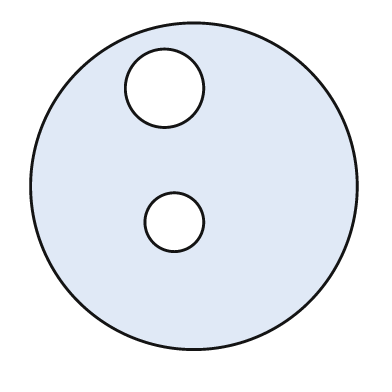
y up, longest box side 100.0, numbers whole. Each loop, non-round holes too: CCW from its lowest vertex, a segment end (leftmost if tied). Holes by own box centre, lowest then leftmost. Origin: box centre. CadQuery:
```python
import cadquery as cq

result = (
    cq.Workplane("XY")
    .moveTo(0.0, 0.0)
    .circle(50.0)
    .moveTo(-6.0, -11.0)
    .circle(9.0)
    .moveTo(-9.0, 30.0)
    .circle(12.0)
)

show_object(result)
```